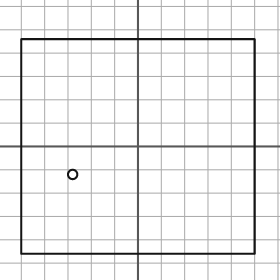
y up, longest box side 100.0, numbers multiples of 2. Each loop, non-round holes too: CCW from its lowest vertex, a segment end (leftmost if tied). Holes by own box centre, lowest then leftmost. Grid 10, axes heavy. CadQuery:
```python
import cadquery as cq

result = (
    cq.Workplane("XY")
    .moveTo(-50.0, -46.0)
    .lineTo(50.0, -46.0)
    .lineTo(50.0, 46.0)
    .lineTo(-50.0, 46.0)
    .close()
    .moveTo(-28.0, -12.0)
    .circle(2.0)
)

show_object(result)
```